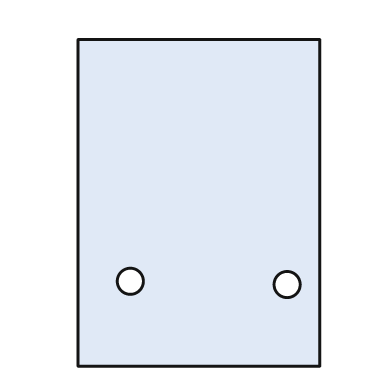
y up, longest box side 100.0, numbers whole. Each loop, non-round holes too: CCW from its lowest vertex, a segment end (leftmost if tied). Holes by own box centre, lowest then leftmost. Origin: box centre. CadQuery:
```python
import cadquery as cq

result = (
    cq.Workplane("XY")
    .moveTo(-37.0, -50.0)
    .lineTo(37.0, -50.0)
    .lineTo(37.0, 50.0)
    .lineTo(-37.0, 50.0)
    .close()
    .moveTo(27.0, -25.0)
    .circle(4.0)
    .moveTo(-21.0, -24.0)
    .circle(4.0)
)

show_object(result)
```